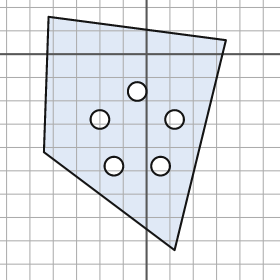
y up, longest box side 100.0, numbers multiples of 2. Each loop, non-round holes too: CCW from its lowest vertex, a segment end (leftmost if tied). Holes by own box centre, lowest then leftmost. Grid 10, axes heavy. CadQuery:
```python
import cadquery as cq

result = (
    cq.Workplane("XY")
    .moveTo(12.0, -84.0)
    .lineTo(34.0, 6.0)
    .lineTo(-42.0, 16.0)
    .lineTo(-44.0, -42.0)
    .close()
    .moveTo(-14.0, -48.0)
    .circle(4.0)
    .moveTo(6.0, -48.0)
    .circle(4.0)
    .moveTo(-20.0, -28.0)
    .circle(4.0)
    .moveTo(12.0, -28.0)
    .circle(4.0)
    .moveTo(-4.0, -16.0)
    .circle(4.0)
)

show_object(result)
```